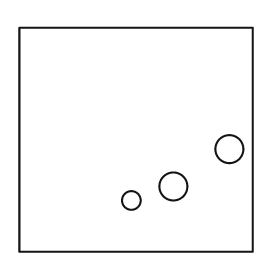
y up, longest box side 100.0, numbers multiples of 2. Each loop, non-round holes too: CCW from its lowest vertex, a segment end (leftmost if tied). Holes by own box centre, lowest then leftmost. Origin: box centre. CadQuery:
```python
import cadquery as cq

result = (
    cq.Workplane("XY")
    .moveTo(-50.0, -48.0)
    .lineTo(50.0, -48.0)
    .lineTo(50.0, 48.0)
    .lineTo(-50.0, 48.0)
    .close()
    .moveTo(-2.0, -26.0)
    .circle(4.0)
    .moveTo(16.0, -20.0)
    .circle(6.0)
    .moveTo(40.0, -4.0)
    .circle(6.0)
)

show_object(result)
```